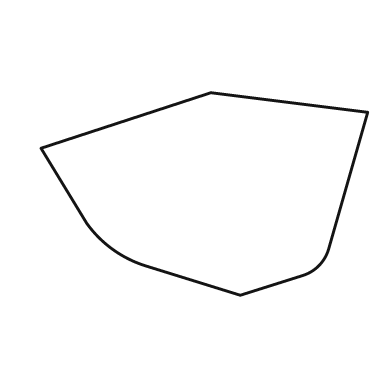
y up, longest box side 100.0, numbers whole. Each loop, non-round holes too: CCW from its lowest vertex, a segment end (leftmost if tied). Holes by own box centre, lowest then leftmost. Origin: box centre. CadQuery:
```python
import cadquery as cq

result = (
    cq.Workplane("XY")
    .moveTo(11.0, -31.0)
    .lineTo(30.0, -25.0)
    .threePointArc((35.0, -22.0), (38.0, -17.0))
    .lineTo(50.0, 25.0)
    .lineTo(2.0, 31.0)
    .lineTo(-50.0, 14.0)
    .lineTo(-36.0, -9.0)
    .threePointArc((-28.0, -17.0), (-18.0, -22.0))
    .close()
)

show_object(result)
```